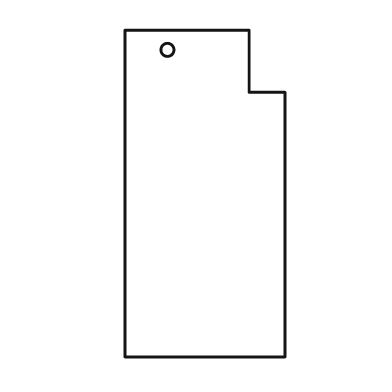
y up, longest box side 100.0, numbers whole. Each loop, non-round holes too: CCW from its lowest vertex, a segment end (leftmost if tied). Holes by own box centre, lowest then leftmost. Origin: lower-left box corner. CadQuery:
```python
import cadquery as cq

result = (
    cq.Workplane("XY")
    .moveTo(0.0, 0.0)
    .lineTo(49.0, 0.0)
    .lineTo(49.0, 81.0)
    .lineTo(38.0, 81.0)
    .lineTo(38.0, 100.0)
    .lineTo(0.0, 100.0)
    .close()
    .moveTo(13.0, 94.0)
    .circle(2.0)
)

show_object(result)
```